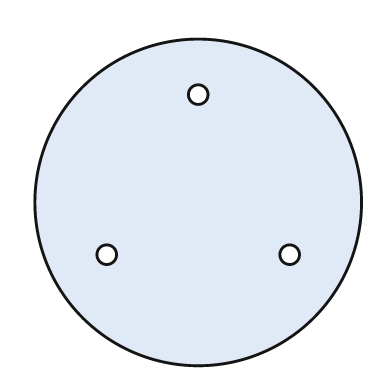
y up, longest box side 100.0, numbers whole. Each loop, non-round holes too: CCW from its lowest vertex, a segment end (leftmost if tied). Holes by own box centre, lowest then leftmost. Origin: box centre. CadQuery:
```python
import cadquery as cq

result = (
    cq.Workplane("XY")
    .moveTo(0.0, 0.0)
    .circle(50.0)
    .moveTo(-28.0, -16.0)
    .circle(3.0)
    .moveTo(28.0, -16.0)
    .circle(3.0)
    .moveTo(0.0, 33.0)
    .circle(3.0)
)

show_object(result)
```